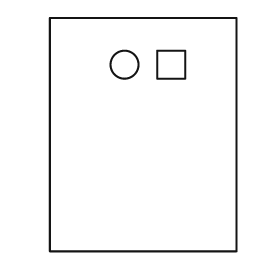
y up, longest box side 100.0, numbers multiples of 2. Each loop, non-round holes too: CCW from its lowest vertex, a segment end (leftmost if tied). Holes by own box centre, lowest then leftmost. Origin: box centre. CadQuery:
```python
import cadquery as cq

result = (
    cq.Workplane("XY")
    .moveTo(-40.0, -50.0)
    .lineTo(40.0, -50.0)
    .lineTo(40.0, 50.0)
    .lineTo(-40.0, 50.0)
    .close()
    .moveTo(-8.0, 30.0)
    .circle(6.0)
    .moveTo(6.0, 24.0)
    .lineTo(18.0, 24.0)
    .lineTo(18.0, 36.0)
    .lineTo(6.0, 36.0)
    .close()
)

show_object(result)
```